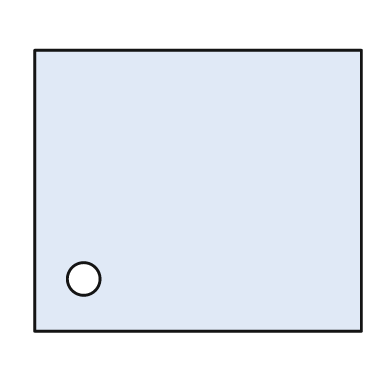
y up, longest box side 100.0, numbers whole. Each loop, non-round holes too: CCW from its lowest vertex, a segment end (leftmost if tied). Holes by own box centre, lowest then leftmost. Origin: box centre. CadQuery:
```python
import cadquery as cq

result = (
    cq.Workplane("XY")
    .moveTo(-50.0, -43.0)
    .lineTo(50.0, -43.0)
    .lineTo(50.0, 43.0)
    .lineTo(-50.0, 43.0)
    .close()
    .moveTo(-35.0, -27.0)
    .circle(5.0)
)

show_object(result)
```